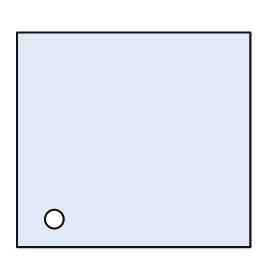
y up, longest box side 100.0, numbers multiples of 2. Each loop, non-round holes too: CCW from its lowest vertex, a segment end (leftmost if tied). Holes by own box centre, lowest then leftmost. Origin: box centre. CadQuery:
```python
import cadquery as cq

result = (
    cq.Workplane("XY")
    .moveTo(-50.0, -46.0)
    .lineTo(50.0, -46.0)
    .lineTo(50.0, 46.0)
    .lineTo(-50.0, 46.0)
    .close()
    .moveTo(-34.0, -34.0)
    .circle(4.0)
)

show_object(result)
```